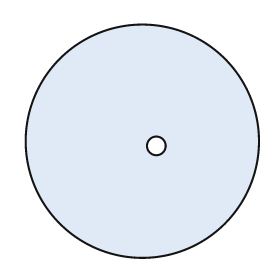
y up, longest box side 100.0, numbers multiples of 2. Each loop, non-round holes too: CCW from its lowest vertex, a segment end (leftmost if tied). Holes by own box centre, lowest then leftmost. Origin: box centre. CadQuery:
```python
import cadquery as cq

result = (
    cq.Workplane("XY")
    .moveTo(0.0, 0.0)
    .circle(50.0)
    .moveTo(6.0, -2.0)
    .circle(4.0)
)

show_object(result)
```